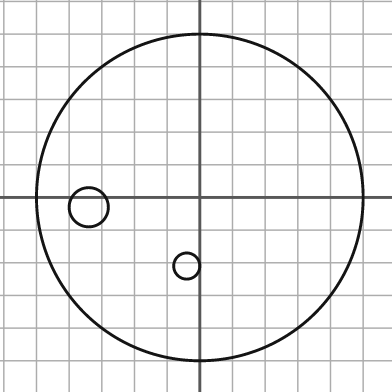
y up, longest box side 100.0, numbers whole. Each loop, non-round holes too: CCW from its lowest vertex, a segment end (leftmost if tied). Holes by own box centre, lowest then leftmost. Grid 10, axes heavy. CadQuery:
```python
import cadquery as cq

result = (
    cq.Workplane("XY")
    .moveTo(0.0, 0.0)
    .circle(50.0)
    .moveTo(-4.0, -21.0)
    .circle(4.0)
    .moveTo(-34.0, -3.0)
    .circle(6.0)
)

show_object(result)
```